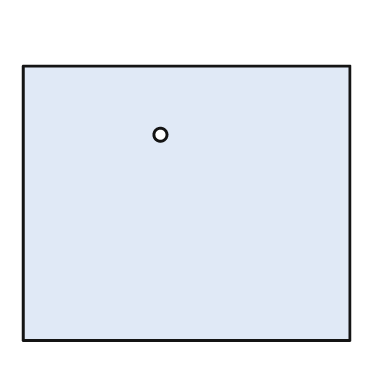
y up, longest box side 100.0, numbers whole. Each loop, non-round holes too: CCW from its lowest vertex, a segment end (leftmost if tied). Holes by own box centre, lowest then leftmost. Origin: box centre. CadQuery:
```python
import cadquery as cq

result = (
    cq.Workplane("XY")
    .moveTo(-50.0, -42.0)
    .lineTo(50.0, -42.0)
    .lineTo(50.0, 42.0)
    .lineTo(-50.0, 42.0)
    .close()
    .moveTo(-8.0, 21.0)
    .circle(2.0)
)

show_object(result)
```